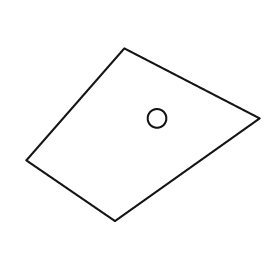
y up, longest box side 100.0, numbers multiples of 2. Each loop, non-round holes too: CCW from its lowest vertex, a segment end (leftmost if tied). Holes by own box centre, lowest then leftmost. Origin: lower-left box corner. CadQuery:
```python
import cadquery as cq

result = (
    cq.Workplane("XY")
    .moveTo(38.0, 0.0)
    .lineTo(100.0, 44.0)
    .lineTo(42.0, 74.0)
    .lineTo(0.0, 26.0)
    .close()
    .moveTo(56.0, 44.0)
    .circle(4.0)
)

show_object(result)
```